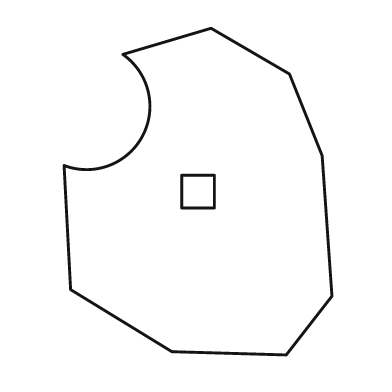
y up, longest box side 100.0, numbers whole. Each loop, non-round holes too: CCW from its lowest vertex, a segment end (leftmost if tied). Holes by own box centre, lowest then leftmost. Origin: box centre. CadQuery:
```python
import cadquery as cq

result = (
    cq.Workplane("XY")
    .moveTo(27.0, -50.0)
    .lineTo(41.0, -32.0)
    .lineTo(38.0, 11.0)
    .lineTo(28.0, 36.0)
    .lineTo(4.0, 50.0)
    .lineTo(-23.0, 42.0)
    .threePointArc((-17.0, 17.0), (-41.0, 8.0))
    .lineTo(-39.0, -30.0)
    .lineTo(-8.0, -49.0)
    .close()
    .moveTo(-5.0, -5.0)
    .lineTo(5.0, -5.0)
    .lineTo(5.0, 5.0)
    .lineTo(-5.0, 5.0)
    .close()
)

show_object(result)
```